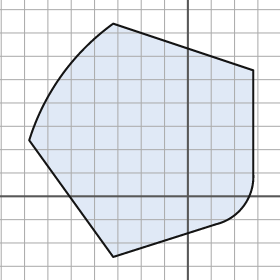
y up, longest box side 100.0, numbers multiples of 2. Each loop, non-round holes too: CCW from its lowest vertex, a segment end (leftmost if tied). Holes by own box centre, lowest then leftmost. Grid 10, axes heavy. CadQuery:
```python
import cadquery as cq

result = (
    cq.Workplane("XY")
    .moveTo(-32.0, -26.0)
    .lineTo(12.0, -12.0)
    .threePointArc((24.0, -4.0), (28.0, 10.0))
    .lineTo(28.0, 54.0)
    .lineTo(-32.0, 74.0)
    .threePointArc((-54.0, 52.0), (-68.0, 24.0))
    .close()
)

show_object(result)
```